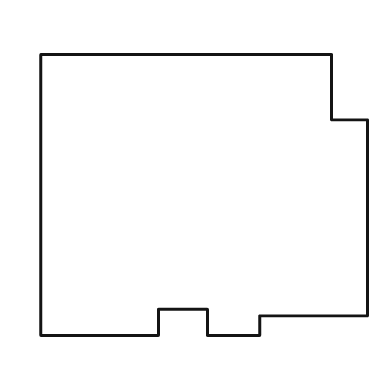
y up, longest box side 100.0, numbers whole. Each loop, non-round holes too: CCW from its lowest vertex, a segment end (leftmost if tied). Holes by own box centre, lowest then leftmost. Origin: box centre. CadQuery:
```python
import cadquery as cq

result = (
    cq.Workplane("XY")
    .moveTo(-50.0, -43.0)
    .lineTo(-14.0, -43.0)
    .lineTo(-14.0, -35.0)
    .lineTo(1.0, -35.0)
    .lineTo(1.0, -43.0)
    .lineTo(17.0, -43.0)
    .lineTo(17.0, -37.0)
    .lineTo(50.0, -37.0)
    .lineTo(50.0, 23.0)
    .lineTo(39.0, 23.0)
    .lineTo(39.0, 43.0)
    .lineTo(-50.0, 43.0)
    .close()
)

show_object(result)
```